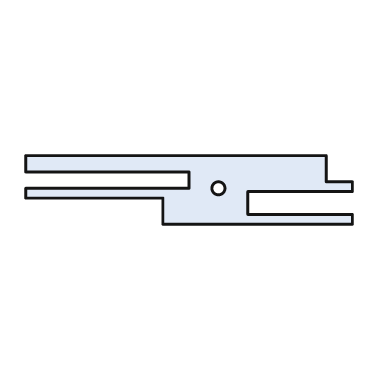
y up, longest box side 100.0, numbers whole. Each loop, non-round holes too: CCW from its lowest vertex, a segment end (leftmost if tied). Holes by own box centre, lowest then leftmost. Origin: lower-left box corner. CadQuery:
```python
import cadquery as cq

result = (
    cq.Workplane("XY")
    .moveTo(42.0, 0.0)
    .lineTo(100.0, 0.0)
    .lineTo(100.0, 3.0)
    .lineTo(68.0, 3.0)
    .lineTo(68.0, 10.0)
    .lineTo(100.0, 10.0)
    .lineTo(100.0, 13.0)
    .lineTo(92.0, 13.0)
    .lineTo(92.0, 21.0)
    .lineTo(0.0, 21.0)
    .lineTo(0.0, 16.0)
    .lineTo(50.0, 16.0)
    .lineTo(50.0, 11.0)
    .lineTo(0.0, 11.0)
    .lineTo(0.0, 8.0)
    .lineTo(42.0, 8.0)
    .close()
    .moveTo(59.0, 11.0)
    .circle(2.0)
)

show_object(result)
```